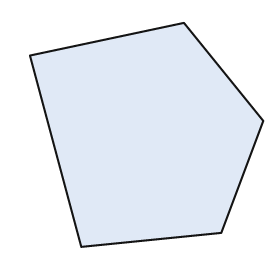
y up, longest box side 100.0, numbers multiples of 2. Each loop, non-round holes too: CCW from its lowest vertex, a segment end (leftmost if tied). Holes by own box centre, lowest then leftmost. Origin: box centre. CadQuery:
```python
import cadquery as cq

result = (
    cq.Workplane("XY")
    .moveTo(-28.0, -48.0)
    .lineTo(32.0, -42.0)
    .lineTo(50.0, 6.0)
    .lineTo(16.0, 48.0)
    .lineTo(-50.0, 34.0)
    .close()
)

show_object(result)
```